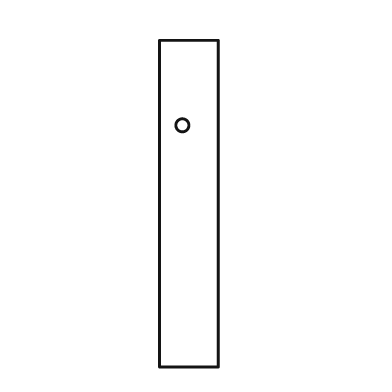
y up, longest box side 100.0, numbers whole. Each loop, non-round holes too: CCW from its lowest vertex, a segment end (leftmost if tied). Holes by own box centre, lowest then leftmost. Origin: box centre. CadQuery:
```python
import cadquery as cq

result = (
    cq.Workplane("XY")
    .moveTo(-9.0, -50.0)
    .lineTo(9.0, -50.0)
    .lineTo(9.0, 50.0)
    .lineTo(-9.0, 50.0)
    .close()
    .moveTo(-2.0, 24.0)
    .circle(2.0)
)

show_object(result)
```